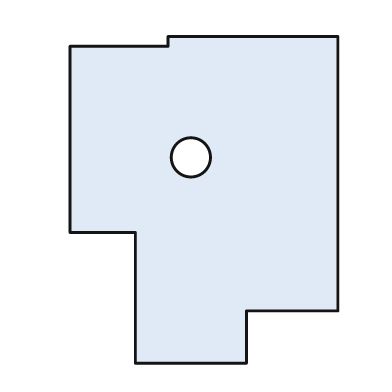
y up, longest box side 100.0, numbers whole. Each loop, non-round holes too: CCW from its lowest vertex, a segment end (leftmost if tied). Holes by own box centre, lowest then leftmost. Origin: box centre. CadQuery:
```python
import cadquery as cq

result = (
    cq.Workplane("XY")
    .moveTo(-21.0, -50.0)
    .lineTo(13.0, -50.0)
    .lineTo(13.0, -34.0)
    .lineTo(41.0, -34.0)
    .lineTo(41.0, 50.0)
    .lineTo(-11.0, 50.0)
    .lineTo(-11.0, 47.0)
    .lineTo(-41.0, 47.0)
    .lineTo(-41.0, -10.0)
    .lineTo(-21.0, -10.0)
    .close()
    .moveTo(-4.0, 13.0)
    .circle(6.0)
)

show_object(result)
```